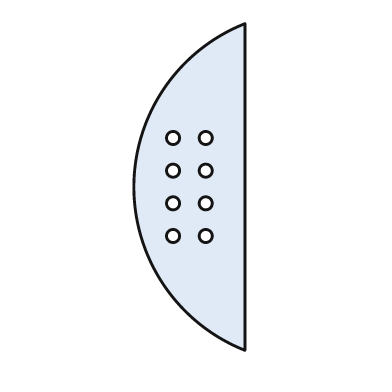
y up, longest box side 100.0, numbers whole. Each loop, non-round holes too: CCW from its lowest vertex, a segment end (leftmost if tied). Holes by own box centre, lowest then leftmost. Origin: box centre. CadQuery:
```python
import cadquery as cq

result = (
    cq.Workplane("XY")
    .moveTo(17.0, -50.0)
    .lineTo(17.0, 50.0)
    .threePointArc((-17.0, 0.0), (17.0, -50.0))
    .close()
    .moveTo(-5.0, -15.0)
    .circle(2.0)
    .moveTo(5.0, -15.0)
    .circle(2.0)
    .moveTo(-5.0, -5.0)
    .circle(2.0)
    .moveTo(5.0, -5.0)
    .circle(2.0)
    .moveTo(-5.0, 5.0)
    .circle(2.0)
    .moveTo(5.0, 5.0)
    .circle(2.0)
    .moveTo(-5.0, 15.0)
    .circle(2.0)
    .moveTo(5.0, 15.0)
    .circle(2.0)
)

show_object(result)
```